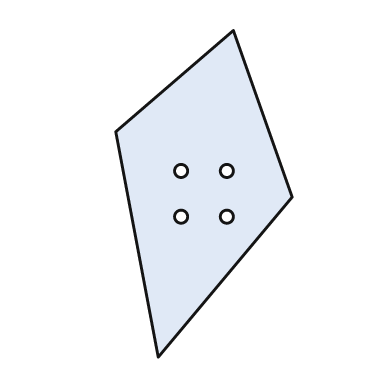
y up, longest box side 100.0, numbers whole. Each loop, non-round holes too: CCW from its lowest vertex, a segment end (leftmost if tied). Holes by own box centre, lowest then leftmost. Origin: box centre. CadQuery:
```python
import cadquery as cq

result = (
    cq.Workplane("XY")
    .moveTo(-14.0, -50.0)
    .lineTo(27.0, -1.0)
    .lineTo(9.0, 50.0)
    .lineTo(-27.0, 19.0)
    .close()
    .moveTo(-7.0, -7.0)
    .circle(2.0)
    .moveTo(7.0, -7.0)
    .circle(2.0)
    .moveTo(-7.0, 7.0)
    .circle(2.0)
    .moveTo(7.0, 7.0)
    .circle(2.0)
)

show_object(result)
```